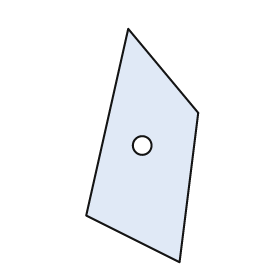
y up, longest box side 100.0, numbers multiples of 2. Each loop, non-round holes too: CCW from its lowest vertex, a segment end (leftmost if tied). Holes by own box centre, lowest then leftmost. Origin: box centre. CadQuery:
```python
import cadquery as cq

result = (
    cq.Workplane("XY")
    .moveTo(16.0, -50.0)
    .lineTo(24.0, 14.0)
    .lineTo(-6.0, 50.0)
    .lineTo(-24.0, -30.0)
    .close()
    .moveTo(0.0, 0.0)
    .circle(4.0)
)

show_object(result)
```